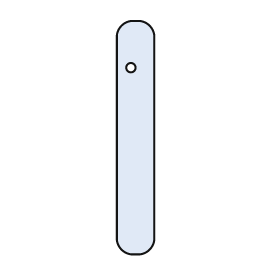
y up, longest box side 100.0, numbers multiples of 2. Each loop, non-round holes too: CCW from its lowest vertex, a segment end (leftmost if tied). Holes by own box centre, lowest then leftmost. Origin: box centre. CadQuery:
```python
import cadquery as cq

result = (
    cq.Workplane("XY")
    .moveTo(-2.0, -50.0)
    .lineTo(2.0, -50.0)
    .threePointArc((6.0, -48.0), (8.0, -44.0))
    .lineTo(8.0, 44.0)
    .threePointArc((6.0, 48.0), (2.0, 50.0))
    .lineTo(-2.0, 50.0)
    .threePointArc((-6.0, 48.0), (-8.0, 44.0))
    .lineTo(-8.0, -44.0)
    .threePointArc((-6.0, -48.0), (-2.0, -50.0))
    .close()
    .moveTo(-2.0, 30.0)
    .circle(2.0)
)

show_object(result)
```